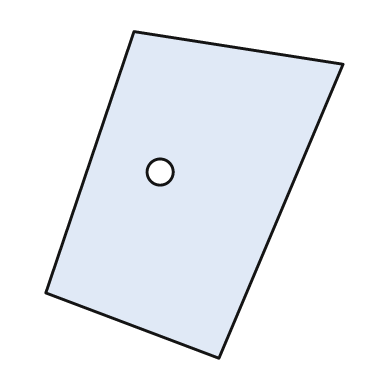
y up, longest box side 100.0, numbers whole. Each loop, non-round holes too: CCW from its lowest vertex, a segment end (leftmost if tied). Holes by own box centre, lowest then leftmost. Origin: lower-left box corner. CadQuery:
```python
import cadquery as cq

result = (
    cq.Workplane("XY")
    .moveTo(53.0, 0.0)
    .lineTo(91.0, 90.0)
    .lineTo(27.0, 100.0)
    .lineTo(0.0, 20.0)
    .close()
    .moveTo(35.0, 57.0)
    .circle(4.0)
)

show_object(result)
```